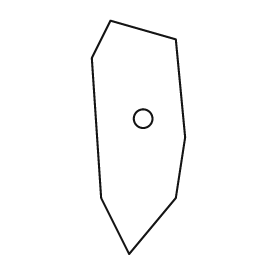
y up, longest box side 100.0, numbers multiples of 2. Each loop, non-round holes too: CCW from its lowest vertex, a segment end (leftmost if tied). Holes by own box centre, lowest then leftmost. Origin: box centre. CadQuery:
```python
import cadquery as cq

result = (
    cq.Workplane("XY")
    .moveTo(-4.0, -50.0)
    .lineTo(16.0, -26.0)
    .lineTo(20.0, 0.0)
    .lineTo(16.0, 42.0)
    .lineTo(-12.0, 50.0)
    .lineTo(-20.0, 34.0)
    .lineTo(-16.0, -26.0)
    .close()
    .moveTo(2.0, 8.0)
    .circle(4.0)
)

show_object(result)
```